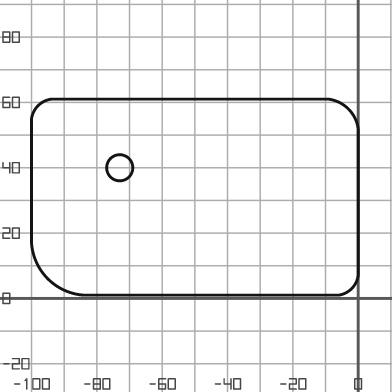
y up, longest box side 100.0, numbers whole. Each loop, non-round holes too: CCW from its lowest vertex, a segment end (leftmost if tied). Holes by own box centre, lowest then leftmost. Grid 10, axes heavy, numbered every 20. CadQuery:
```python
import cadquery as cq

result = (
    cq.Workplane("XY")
    .moveTo(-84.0, 1.0)
    .lineTo(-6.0, 1.0)
    .threePointArc((-2.0, 3.0), (0.0, 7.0))
    .lineTo(0.0, 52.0)
    .threePointArc((-3.0, 58.0), (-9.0, 61.0))
    .lineTo(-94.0, 61.0)
    .threePointArc((-98.0, 59.0), (-100.0, 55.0))
    .lineTo(-100.0, 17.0)
    .threePointArc((-95.0, 6.0), (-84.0, 1.0))
    .close()
    .moveTo(-73.0, 40.0)
    .circle(4.0)
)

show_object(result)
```